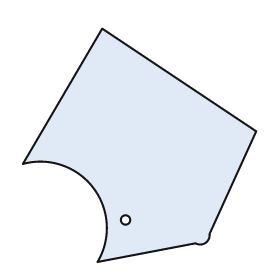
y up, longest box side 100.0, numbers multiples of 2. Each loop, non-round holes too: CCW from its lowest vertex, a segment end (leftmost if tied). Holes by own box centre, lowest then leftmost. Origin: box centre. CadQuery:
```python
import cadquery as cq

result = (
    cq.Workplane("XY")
    .moveTo(-18.0, -50.0)
    .lineTo(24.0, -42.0)
    .threePointArc((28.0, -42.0), (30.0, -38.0))
    .lineTo(50.0, 6.0)
    .lineTo(-16.0, 50.0)
    .lineTo(-50.0, -8.0)
    .threePointArc((-20.0, -18.0), (-18.0, -50.0))
    .close()
    .moveTo(-6.0, -32.0)
    .circle(2.0)
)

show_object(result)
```